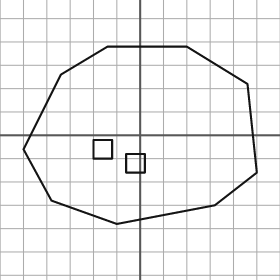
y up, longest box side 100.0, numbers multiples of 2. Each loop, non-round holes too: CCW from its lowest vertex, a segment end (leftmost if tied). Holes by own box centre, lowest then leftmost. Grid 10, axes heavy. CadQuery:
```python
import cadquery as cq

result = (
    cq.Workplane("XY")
    .moveTo(-10.0, -38.0)
    .lineTo(32.0, -30.0)
    .lineTo(50.0, -16.0)
    .lineTo(46.0, 22.0)
    .lineTo(20.0, 38.0)
    .lineTo(-14.0, 38.0)
    .lineTo(-34.0, 26.0)
    .lineTo(-50.0, -6.0)
    .lineTo(-38.0, -28.0)
    .close()
    .moveTo(-6.0, -16.0)
    .lineTo(2.0, -16.0)
    .lineTo(2.0, -8.0)
    .lineTo(-6.0, -8.0)
    .close()
    .moveTo(-20.0, -10.0)
    .lineTo(-12.0, -10.0)
    .lineTo(-12.0, -2.0)
    .lineTo(-20.0, -2.0)
    .close()
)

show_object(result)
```